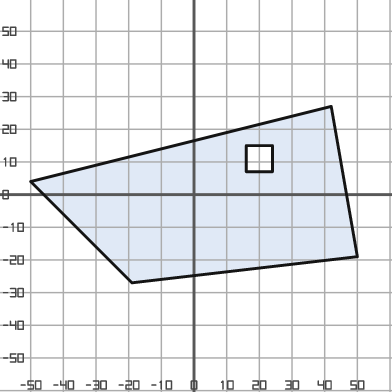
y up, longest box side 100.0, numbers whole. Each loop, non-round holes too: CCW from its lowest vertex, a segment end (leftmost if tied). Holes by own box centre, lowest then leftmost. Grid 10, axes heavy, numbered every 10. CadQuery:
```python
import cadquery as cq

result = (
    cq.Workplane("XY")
    .moveTo(-19.0, -27.0)
    .lineTo(50.0, -19.0)
    .lineTo(42.0, 27.0)
    .lineTo(-50.0, 4.0)
    .close()
    .moveTo(16.0, 7.0)
    .lineTo(24.0, 7.0)
    .lineTo(24.0, 15.0)
    .lineTo(16.0, 15.0)
    .close()
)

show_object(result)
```